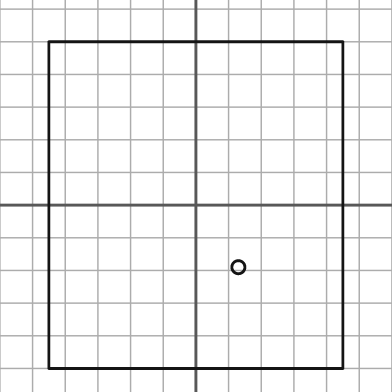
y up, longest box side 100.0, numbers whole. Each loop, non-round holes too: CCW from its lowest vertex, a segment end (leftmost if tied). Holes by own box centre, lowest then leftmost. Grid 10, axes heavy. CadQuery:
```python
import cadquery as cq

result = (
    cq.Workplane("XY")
    .moveTo(-45.0, -50.0)
    .lineTo(45.0, -50.0)
    .lineTo(45.0, 50.0)
    .lineTo(-45.0, 50.0)
    .close()
    .moveTo(13.0, -19.0)
    .circle(2.0)
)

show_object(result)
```